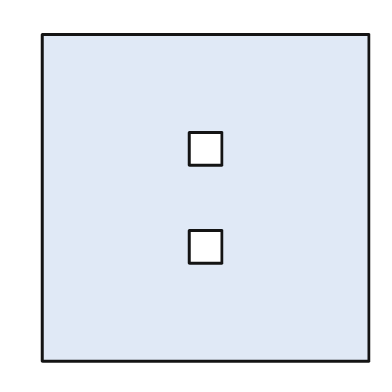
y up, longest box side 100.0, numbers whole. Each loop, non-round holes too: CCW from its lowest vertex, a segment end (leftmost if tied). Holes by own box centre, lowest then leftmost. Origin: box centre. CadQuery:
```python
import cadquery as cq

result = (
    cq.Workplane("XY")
    .moveTo(-50.0, -50.0)
    .lineTo(50.0, -50.0)
    .lineTo(50.0, 50.0)
    .lineTo(-50.0, 50.0)
    .close()
    .moveTo(-5.0, -20.0)
    .lineTo(5.0, -20.0)
    .lineTo(5.0, -10.0)
    .lineTo(-5.0, -10.0)
    .close()
    .moveTo(-5.0, 10.0)
    .lineTo(5.0, 10.0)
    .lineTo(5.0, 20.0)
    .lineTo(-5.0, 20.0)
    .close()
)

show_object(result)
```